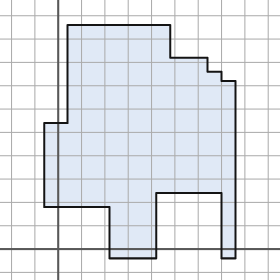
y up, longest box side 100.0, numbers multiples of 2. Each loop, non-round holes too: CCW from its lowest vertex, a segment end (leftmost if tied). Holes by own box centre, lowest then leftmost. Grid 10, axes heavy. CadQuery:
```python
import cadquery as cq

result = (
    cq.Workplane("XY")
    .moveTo(22.0, -4.0)
    .lineTo(42.0, -4.0)
    .lineTo(42.0, 24.0)
    .lineTo(70.0, 24.0)
    .lineTo(70.0, -4.0)
    .lineTo(76.0, -4.0)
    .lineTo(76.0, 72.0)
    .lineTo(70.0, 72.0)
    .lineTo(70.0, 76.0)
    .lineTo(64.0, 76.0)
    .lineTo(64.0, 82.0)
    .lineTo(48.0, 82.0)
    .lineTo(48.0, 96.0)
    .lineTo(4.0, 96.0)
    .lineTo(4.0, 54.0)
    .lineTo(-6.0, 54.0)
    .lineTo(-6.0, 18.0)
    .lineTo(22.0, 18.0)
    .close()
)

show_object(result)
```